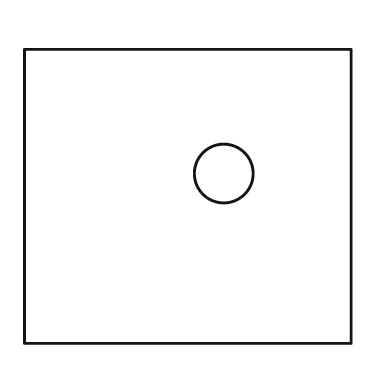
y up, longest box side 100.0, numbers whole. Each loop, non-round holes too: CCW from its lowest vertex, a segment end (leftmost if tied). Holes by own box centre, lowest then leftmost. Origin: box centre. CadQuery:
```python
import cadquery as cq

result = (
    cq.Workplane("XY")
    .moveTo(-50.0, -45.0)
    .lineTo(50.0, -45.0)
    .lineTo(50.0, 45.0)
    .lineTo(-50.0, 45.0)
    .close()
    .moveTo(11.0, 7.0)
    .circle(9.0)
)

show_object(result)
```